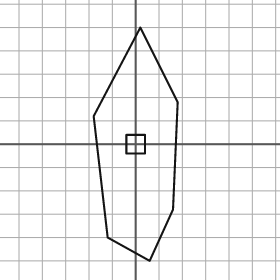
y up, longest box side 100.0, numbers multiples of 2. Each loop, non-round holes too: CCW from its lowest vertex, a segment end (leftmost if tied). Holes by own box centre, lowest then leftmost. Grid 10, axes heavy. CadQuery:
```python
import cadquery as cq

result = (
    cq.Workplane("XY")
    .moveTo(6.0, -50.0)
    .lineTo(16.0, -28.0)
    .lineTo(18.0, 18.0)
    .lineTo(2.0, 50.0)
    .lineTo(-18.0, 12.0)
    .lineTo(-12.0, -40.0)
    .close()
    .moveTo(-4.0, -4.0)
    .lineTo(4.0, -4.0)
    .lineTo(4.0, 4.0)
    .lineTo(-4.0, 4.0)
    .close()
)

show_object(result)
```